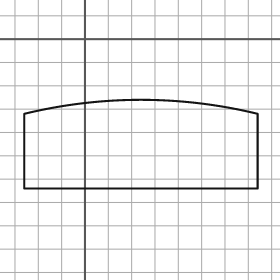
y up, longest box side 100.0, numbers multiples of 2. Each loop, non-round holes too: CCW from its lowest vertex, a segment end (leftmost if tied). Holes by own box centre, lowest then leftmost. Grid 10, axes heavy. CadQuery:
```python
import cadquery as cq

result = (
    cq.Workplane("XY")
    .moveTo(-26.0, -64.0)
    .lineTo(74.0, -64.0)
    .lineTo(74.0, -32.0)
    .threePointArc((24.0, -26.0), (-26.0, -32.0))
    .close()
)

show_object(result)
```